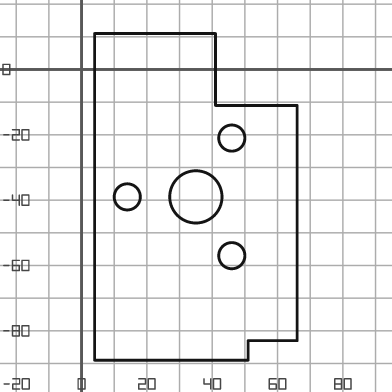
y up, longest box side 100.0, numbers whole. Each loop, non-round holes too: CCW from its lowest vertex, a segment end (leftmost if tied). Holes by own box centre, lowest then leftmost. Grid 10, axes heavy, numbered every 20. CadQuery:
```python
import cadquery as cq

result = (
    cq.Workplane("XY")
    .moveTo(4.0, -89.0)
    .lineTo(51.0, -89.0)
    .lineTo(51.0, -83.0)
    .lineTo(66.0, -83.0)
    .lineTo(66.0, -11.0)
    .lineTo(41.0, -11.0)
    .lineTo(41.0, 11.0)
    .lineTo(4.0, 11.0)
    .close()
    .moveTo(46.0, -57.0)
    .circle(4.0)
    .moveTo(14.0, -39.0)
    .circle(4.0)
    .moveTo(35.0, -39.0)
    .circle(8.0)
    .moveTo(46.0, -21.0)
    .circle(4.0)
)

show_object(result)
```